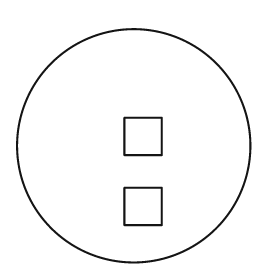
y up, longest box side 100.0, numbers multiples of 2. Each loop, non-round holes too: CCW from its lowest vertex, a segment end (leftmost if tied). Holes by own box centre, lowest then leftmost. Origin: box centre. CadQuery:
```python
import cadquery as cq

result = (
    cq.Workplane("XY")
    .moveTo(0.0, 0.0)
    .circle(50.0)
    .moveTo(-4.0, -34.0)
    .lineTo(12.0, -34.0)
    .lineTo(12.0, -18.0)
    .lineTo(-4.0, -18.0)
    .close()
    .moveTo(-4.0, -4.0)
    .lineTo(12.0, -4.0)
    .lineTo(12.0, 12.0)
    .lineTo(-4.0, 12.0)
    .close()
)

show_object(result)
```